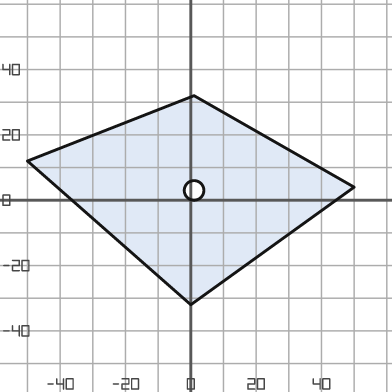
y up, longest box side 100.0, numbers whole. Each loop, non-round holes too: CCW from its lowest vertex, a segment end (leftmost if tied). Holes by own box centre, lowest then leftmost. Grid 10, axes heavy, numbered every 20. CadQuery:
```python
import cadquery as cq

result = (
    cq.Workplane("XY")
    .moveTo(0.0, -32.0)
    .lineTo(50.0, 4.0)
    .lineTo(1.0, 32.0)
    .lineTo(-50.0, 12.0)
    .close()
    .moveTo(1.0, 3.0)
    .circle(3.0)
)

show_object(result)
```